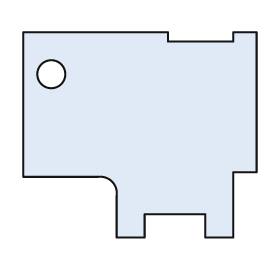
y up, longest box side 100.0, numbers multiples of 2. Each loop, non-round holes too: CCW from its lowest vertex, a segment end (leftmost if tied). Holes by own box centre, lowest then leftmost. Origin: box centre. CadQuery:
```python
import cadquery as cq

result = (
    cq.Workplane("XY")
    .moveTo(-10.0, -44.0)
    .lineTo(2.0, -44.0)
    .lineTo(2.0, -34.0)
    .lineTo(28.0, -34.0)
    .lineTo(28.0, -44.0)
    .lineTo(40.0, -44.0)
    .lineTo(40.0, -16.0)
    .lineTo(50.0, -16.0)
    .lineTo(50.0, 44.0)
    .lineTo(40.0, 44.0)
    .lineTo(40.0, 40.0)
    .lineTo(12.0, 40.0)
    .lineTo(12.0, 44.0)
    .lineTo(-50.0, 44.0)
    .lineTo(-50.0, -18.0)
    .lineTo(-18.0, -18.0)
    .threePointArc((-12.0, -20.0), (-10.0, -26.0))
    .close()
    .moveTo(-38.0, 26.0)
    .circle(6.0)
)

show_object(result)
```